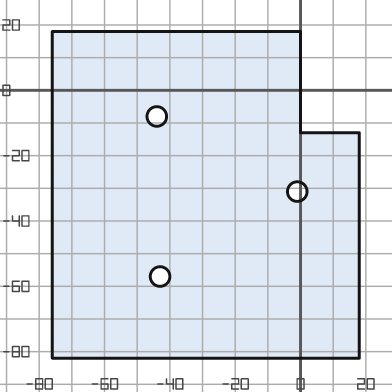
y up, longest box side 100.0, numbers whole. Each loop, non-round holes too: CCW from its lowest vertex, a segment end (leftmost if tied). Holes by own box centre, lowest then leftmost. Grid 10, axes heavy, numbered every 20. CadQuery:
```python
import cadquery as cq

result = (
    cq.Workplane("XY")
    .moveTo(-76.0, -82.0)
    .lineTo(18.0, -82.0)
    .lineTo(18.0, -13.0)
    .lineTo(0.0, -13.0)
    .lineTo(0.0, 18.0)
    .lineTo(-76.0, 18.0)
    .close()
    .moveTo(-43.0, -57.0)
    .circle(3.0)
    .moveTo(-1.0, -31.0)
    .circle(3.0)
    .moveTo(-44.0, -8.0)
    .circle(3.0)
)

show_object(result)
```